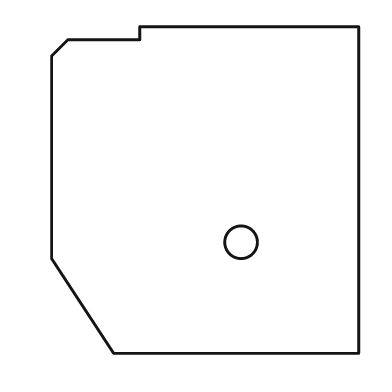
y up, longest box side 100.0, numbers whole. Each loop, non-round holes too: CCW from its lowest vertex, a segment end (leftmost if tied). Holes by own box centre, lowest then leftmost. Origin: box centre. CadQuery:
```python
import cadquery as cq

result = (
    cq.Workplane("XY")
    .moveTo(-28.0, -50.0)
    .lineTo(47.0, -50.0)
    .lineTo(47.0, 50.0)
    .lineTo(-20.0, 50.0)
    .lineTo(-20.0, 46.0)
    .lineTo(-42.0, 46.0)
    .lineTo(-47.0, 41.0)
    .lineTo(-47.0, -21.0)
    .close()
    .moveTo(11.0, -16.0)
    .circle(5.0)
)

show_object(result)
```